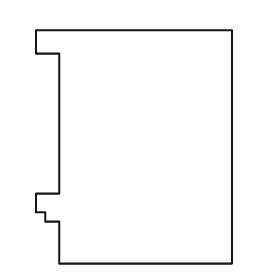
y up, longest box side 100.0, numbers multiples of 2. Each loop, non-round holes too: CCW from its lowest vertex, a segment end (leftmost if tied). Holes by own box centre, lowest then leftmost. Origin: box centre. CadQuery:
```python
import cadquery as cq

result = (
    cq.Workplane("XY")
    .moveTo(-32.0, -50.0)
    .lineTo(42.0, -50.0)
    .lineTo(42.0, 50.0)
    .lineTo(-42.0, 50.0)
    .lineTo(-42.0, 40.0)
    .lineTo(-32.0, 40.0)
    .lineTo(-32.0, -20.0)
    .lineTo(-42.0, -20.0)
    .lineTo(-42.0, -28.0)
    .lineTo(-38.0, -28.0)
    .lineTo(-38.0, -32.0)
    .lineTo(-32.0, -32.0)
    .close()
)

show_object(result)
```